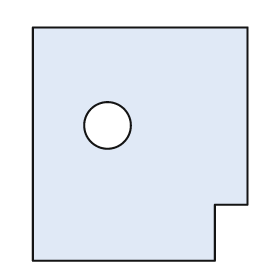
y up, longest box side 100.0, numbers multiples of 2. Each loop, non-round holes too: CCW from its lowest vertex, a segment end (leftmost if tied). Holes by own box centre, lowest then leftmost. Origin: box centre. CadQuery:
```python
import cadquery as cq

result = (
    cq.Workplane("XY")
    .moveTo(-46.0, -50.0)
    .lineTo(32.0, -50.0)
    .lineTo(32.0, -26.0)
    .lineTo(46.0, -26.0)
    .lineTo(46.0, 50.0)
    .lineTo(-46.0, 50.0)
    .close()
    .moveTo(-14.0, 8.0)
    .circle(10.0)
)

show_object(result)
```